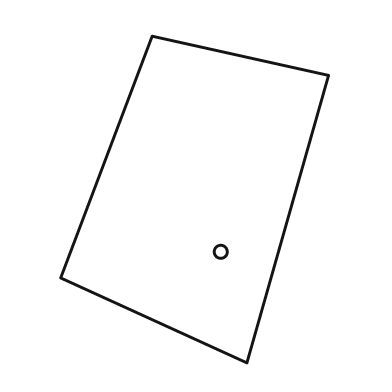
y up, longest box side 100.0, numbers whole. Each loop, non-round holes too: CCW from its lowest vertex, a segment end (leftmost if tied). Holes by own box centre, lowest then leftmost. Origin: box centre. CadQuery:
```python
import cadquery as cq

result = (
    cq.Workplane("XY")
    .moveTo(16.0, -50.0)
    .lineTo(41.0, 38.0)
    .lineTo(-13.0, 50.0)
    .lineTo(-41.0, -24.0)
    .close()
    .moveTo(8.0, -16.0)
    .circle(2.0)
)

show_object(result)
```